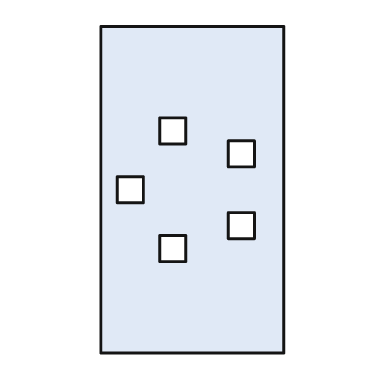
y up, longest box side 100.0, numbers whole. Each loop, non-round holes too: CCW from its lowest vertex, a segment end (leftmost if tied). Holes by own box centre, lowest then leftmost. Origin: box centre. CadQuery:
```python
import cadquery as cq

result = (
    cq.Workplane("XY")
    .moveTo(-28.0, -50.0)
    .lineTo(28.0, -50.0)
    .lineTo(28.0, 50.0)
    .lineTo(-28.0, 50.0)
    .close()
    .moveTo(-10.0, -22.0)
    .lineTo(-2.0, -22.0)
    .lineTo(-2.0, -14.0)
    .lineTo(-10.0, -14.0)
    .close()
    .moveTo(11.0, -15.0)
    .lineTo(19.0, -15.0)
    .lineTo(19.0, -7.0)
    .lineTo(11.0, -7.0)
    .close()
    .moveTo(-23.0, -4.0)
    .lineTo(-15.0, -4.0)
    .lineTo(-15.0, 4.0)
    .lineTo(-23.0, 4.0)
    .close()
    .moveTo(11.0, 7.0)
    .lineTo(19.0, 7.0)
    .lineTo(19.0, 15.0)
    .lineTo(11.0, 15.0)
    .close()
    .moveTo(-10.0, 14.0)
    .lineTo(-2.0, 14.0)
    .lineTo(-2.0, 22.0)
    .lineTo(-10.0, 22.0)
    .close()
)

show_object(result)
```